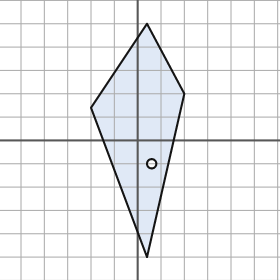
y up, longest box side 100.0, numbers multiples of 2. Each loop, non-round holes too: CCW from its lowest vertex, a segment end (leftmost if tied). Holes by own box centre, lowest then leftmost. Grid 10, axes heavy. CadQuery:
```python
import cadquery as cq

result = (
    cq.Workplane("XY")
    .moveTo(4.0, -50.0)
    .lineTo(20.0, 20.0)
    .lineTo(4.0, 50.0)
    .lineTo(-20.0, 14.0)
    .close()
    .moveTo(6.0, -10.0)
    .circle(2.0)
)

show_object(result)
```